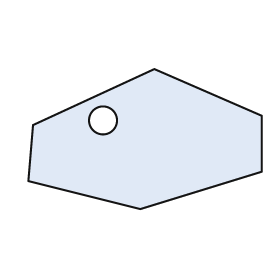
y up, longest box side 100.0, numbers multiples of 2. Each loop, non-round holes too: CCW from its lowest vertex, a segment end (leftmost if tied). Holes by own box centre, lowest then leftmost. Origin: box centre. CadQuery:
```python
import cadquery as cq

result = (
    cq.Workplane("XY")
    .moveTo(-2.0, -30.0)
    .lineTo(50.0, -14.0)
    .lineTo(50.0, 10.0)
    .lineTo(4.0, 30.0)
    .lineTo(-48.0, 6.0)
    .lineTo(-50.0, -18.0)
    .close()
    .moveTo(-18.0, 8.0)
    .circle(6.0)
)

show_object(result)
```